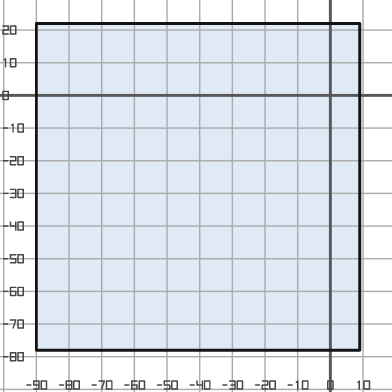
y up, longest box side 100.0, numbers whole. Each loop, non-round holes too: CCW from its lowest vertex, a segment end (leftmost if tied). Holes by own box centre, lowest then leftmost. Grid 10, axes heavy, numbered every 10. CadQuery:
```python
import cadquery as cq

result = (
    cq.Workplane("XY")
    .moveTo(-90.0, -78.0)
    .lineTo(9.0, -78.0)
    .lineTo(9.0, 22.0)
    .lineTo(-90.0, 22.0)
    .close()
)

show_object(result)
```